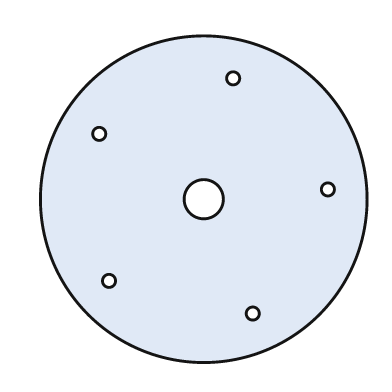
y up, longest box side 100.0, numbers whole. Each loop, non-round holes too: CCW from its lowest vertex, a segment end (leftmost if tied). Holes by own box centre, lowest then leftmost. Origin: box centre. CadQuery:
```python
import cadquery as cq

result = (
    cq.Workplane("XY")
    .moveTo(0.0, 0.0)
    .circle(50.0)
    .moveTo(15.0, -35.0)
    .circle(2.0)
    .moveTo(-29.0, -25.0)
    .circle(2.0)
    .moveTo(0.0, 0.0)
    .circle(6.0)
    .moveTo(38.0, 3.0)
    .circle(2.0)
    .moveTo(-32.0, 20.0)
    .circle(2.0)
    .moveTo(9.0, 37.0)
    .circle(2.0)
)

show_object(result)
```